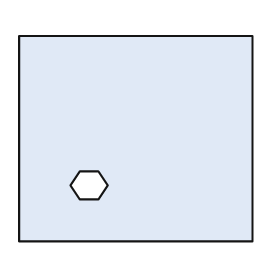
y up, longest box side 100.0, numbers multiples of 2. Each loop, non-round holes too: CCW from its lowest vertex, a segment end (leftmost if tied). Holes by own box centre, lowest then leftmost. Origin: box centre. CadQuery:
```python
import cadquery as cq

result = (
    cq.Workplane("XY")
    .moveTo(-50.0, -44.0)
    .lineTo(50.0, -44.0)
    .lineTo(50.0, 44.0)
    .lineTo(-50.0, 44.0)
    .close()
    .moveTo(-24.0, -26.0)
    .lineTo(-16.0, -26.0)
    .lineTo(-12.0, -20.0)
    .lineTo(-16.0, -14.0)
    .lineTo(-24.0, -14.0)
    .lineTo(-28.0, -20.0)
    .close()
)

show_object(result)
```